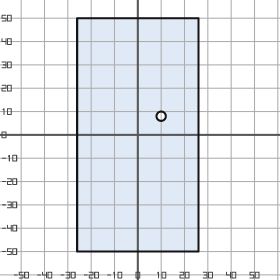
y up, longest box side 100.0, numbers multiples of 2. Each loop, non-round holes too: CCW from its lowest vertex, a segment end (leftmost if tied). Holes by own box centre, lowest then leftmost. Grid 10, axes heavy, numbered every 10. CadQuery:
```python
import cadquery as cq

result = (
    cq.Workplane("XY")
    .moveTo(-26.0, -50.0)
    .lineTo(26.0, -50.0)
    .lineTo(26.0, 50.0)
    .lineTo(-26.0, 50.0)
    .close()
    .moveTo(10.0, 8.0)
    .circle(2.0)
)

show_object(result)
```